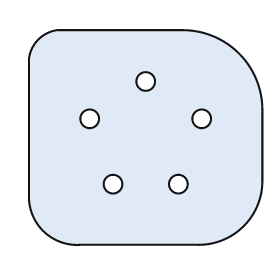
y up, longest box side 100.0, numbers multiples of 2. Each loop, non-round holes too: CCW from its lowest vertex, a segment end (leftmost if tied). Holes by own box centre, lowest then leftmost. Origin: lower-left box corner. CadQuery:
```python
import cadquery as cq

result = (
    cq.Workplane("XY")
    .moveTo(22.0, 0.0)
    .lineTo(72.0, 0.0)
    .threePointArc((92.0, 8.0), (100.0, 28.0))
    .lineTo(100.0, 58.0)
    .threePointArc((90.0, 82.0), (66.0, 92.0))
    .lineTo(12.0, 92.0)
    .threePointArc((4.0, 88.0), (0.0, 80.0))
    .lineTo(0.0, 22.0)
    .threePointArc((6.0, 6.0), (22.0, 0.0))
    .close()
    .moveTo(36.0, 26.0)
    .circle(4.0)
    .moveTo(64.0, 26.0)
    .circle(4.0)
    .moveTo(26.0, 54.0)
    .circle(4.0)
    .moveTo(74.0, 54.0)
    .circle(4.0)
    .moveTo(50.0, 70.0)
    .circle(4.0)
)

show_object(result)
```